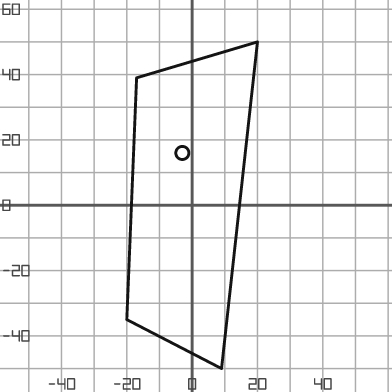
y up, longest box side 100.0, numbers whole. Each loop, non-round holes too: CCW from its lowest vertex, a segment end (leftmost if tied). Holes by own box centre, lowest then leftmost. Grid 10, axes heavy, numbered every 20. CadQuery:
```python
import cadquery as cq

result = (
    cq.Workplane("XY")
    .moveTo(9.0, -50.0)
    .lineTo(20.0, 50.0)
    .lineTo(-17.0, 39.0)
    .lineTo(-20.0, -35.0)
    .close()
    .moveTo(-3.0, 16.0)
    .circle(2.0)
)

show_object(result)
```